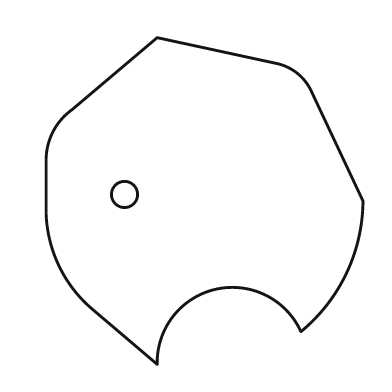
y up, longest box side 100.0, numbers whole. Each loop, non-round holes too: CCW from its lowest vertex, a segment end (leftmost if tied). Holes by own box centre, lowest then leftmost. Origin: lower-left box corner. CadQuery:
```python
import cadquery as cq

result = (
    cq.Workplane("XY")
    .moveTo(34.0, 0.0)
    .threePointArc((52.0, 23.0), (78.0, 10.0))
    .threePointArc((92.0, 28.0), (97.0, 50.0))
    .lineTo(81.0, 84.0)
    .threePointArc((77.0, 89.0), (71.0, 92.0))
    .lineTo(34.0, 100.0)
    .lineTo(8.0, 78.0)
    .threePointArc((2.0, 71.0), (0.0, 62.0))
    .lineTo(0.0, 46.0)
    .threePointArc((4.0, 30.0), (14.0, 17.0))
    .close()
    .moveTo(24.0, 52.0)
    .circle(4.0)
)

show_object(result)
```